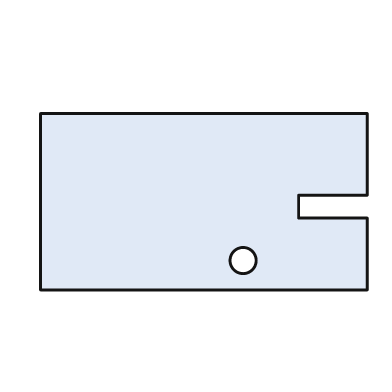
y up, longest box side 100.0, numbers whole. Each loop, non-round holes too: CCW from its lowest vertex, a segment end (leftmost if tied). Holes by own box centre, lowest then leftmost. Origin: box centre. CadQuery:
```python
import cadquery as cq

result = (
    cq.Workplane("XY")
    .moveTo(-50.0, -27.0)
    .lineTo(50.0, -27.0)
    .lineTo(50.0, -5.0)
    .lineTo(29.0, -5.0)
    .lineTo(29.0, 2.0)
    .lineTo(50.0, 2.0)
    .lineTo(50.0, 27.0)
    .lineTo(-50.0, 27.0)
    .close()
    .moveTo(12.0, -18.0)
    .circle(4.0)
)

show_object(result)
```